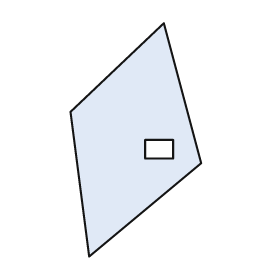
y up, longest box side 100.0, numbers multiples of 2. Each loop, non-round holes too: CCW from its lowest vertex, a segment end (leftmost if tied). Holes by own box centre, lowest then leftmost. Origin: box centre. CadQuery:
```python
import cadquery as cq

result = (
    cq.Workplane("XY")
    .moveTo(-20.0, -50.0)
    .lineTo(28.0, -10.0)
    .lineTo(12.0, 50.0)
    .lineTo(-28.0, 12.0)
    .close()
    .moveTo(4.0, -8.0)
    .lineTo(16.0, -8.0)
    .lineTo(16.0, 0.0)
    .lineTo(4.0, 0.0)
    .close()
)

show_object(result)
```